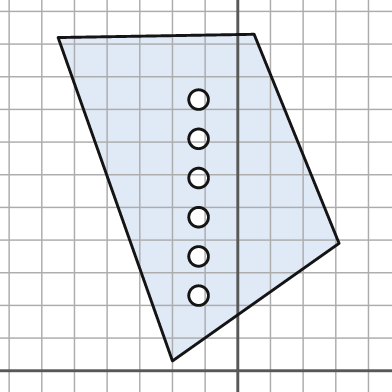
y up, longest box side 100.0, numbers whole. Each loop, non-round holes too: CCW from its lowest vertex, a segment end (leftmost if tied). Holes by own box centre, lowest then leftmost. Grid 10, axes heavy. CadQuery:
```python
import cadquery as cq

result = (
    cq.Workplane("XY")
    .moveTo(-20.0, 3.0)
    .lineTo(31.0, 39.0)
    .lineTo(5.0, 103.0)
    .lineTo(-55.0, 102.0)
    .close()
    .moveTo(-12.0, 23.0)
    .circle(3.0)
    .moveTo(-12.0, 35.0)
    .circle(3.0)
    .moveTo(-12.0, 47.0)
    .circle(3.0)
    .moveTo(-12.0, 59.0)
    .circle(3.0)
    .moveTo(-12.0, 71.0)
    .circle(3.0)
    .moveTo(-12.0, 83.0)
    .circle(3.0)
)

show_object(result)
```